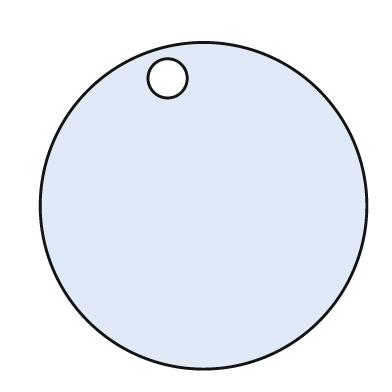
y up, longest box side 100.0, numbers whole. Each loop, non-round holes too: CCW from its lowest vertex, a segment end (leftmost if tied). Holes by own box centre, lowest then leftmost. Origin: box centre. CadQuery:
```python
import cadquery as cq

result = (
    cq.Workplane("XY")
    .moveTo(0.0, 0.0)
    .circle(50.0)
    .moveTo(-11.0, 39.0)
    .circle(6.0)
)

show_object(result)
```